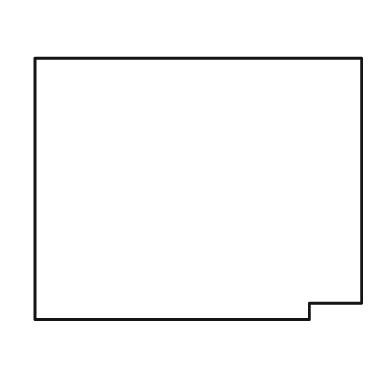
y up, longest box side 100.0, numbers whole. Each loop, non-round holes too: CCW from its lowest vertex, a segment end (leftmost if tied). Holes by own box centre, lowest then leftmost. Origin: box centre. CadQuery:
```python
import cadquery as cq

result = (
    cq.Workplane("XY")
    .moveTo(-50.0, -40.0)
    .lineTo(34.0, -40.0)
    .lineTo(34.0, -35.0)
    .lineTo(50.0, -35.0)
    .lineTo(50.0, 40.0)
    .lineTo(-50.0, 40.0)
    .close()
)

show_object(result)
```